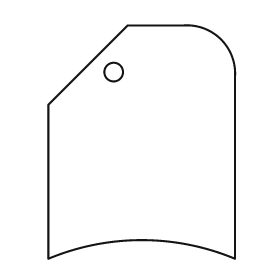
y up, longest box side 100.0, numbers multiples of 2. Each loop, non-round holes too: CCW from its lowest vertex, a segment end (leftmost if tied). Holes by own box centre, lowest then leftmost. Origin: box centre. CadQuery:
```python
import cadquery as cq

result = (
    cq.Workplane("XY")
    .moveTo(-40.0, -50.0)
    .threePointArc((0.0, -42.0), (40.0, -50.0))
    .lineTo(40.0, 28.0)
    .threePointArc((34.0, 44.0), (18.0, 50.0))
    .lineTo(-6.0, 50.0)
    .lineTo(-40.0, 16.0)
    .close()
    .moveTo(-12.0, 30.0)
    .circle(4.0)
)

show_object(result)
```